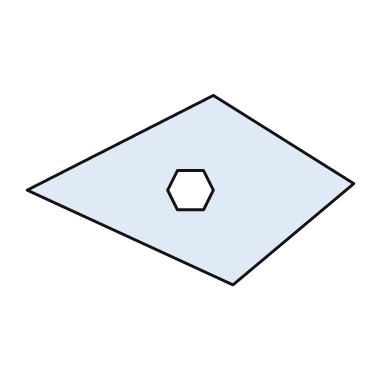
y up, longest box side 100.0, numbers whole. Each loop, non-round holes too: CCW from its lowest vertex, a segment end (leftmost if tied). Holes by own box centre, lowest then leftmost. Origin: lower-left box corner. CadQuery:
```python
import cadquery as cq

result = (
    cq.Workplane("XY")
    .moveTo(63.0, 0.0)
    .lineTo(100.0, 31.0)
    .lineTo(57.0, 58.0)
    .lineTo(0.0, 29.0)
    .close()
    .moveTo(46.0, 23.0)
    .lineTo(54.0, 23.0)
    .lineTo(57.0, 29.0)
    .lineTo(54.0, 35.0)
    .lineTo(46.0, 35.0)
    .lineTo(43.0, 29.0)
    .close()
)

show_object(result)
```